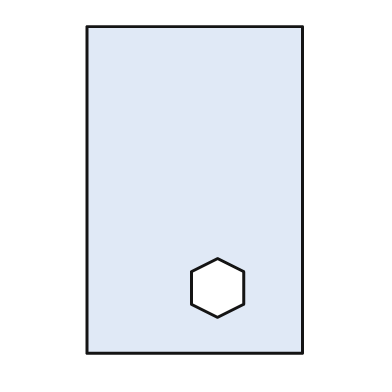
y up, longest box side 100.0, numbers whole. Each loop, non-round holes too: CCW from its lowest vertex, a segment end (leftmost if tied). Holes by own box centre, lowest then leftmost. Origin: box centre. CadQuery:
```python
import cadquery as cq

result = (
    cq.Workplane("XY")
    .moveTo(-33.0, -50.0)
    .lineTo(33.0, -50.0)
    .lineTo(33.0, 50.0)
    .lineTo(-33.0, 50.0)
    .close()
    .moveTo(7.0, -39.0)
    .lineTo(15.0, -35.0)
    .lineTo(15.0, -25.0)
    .lineTo(7.0, -21.0)
    .lineTo(-1.0, -25.0)
    .lineTo(-1.0, -35.0)
    .close()
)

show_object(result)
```